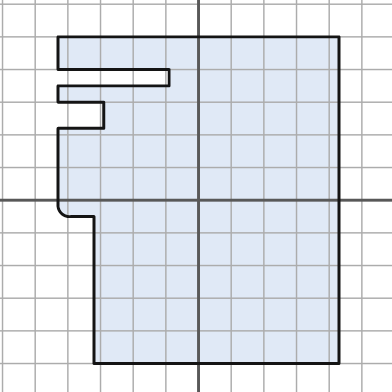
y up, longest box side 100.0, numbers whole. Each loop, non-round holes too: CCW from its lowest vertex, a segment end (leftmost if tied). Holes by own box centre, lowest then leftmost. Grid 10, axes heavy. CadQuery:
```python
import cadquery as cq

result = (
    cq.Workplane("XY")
    .moveTo(-32.0, -50.0)
    .lineTo(43.0, -50.0)
    .lineTo(43.0, 50.0)
    .lineTo(-43.0, 50.0)
    .lineTo(-43.0, 40.0)
    .lineTo(-9.0, 40.0)
    .lineTo(-9.0, 35.0)
    .lineTo(-43.0, 35.0)
    .lineTo(-43.0, 30.0)
    .lineTo(-29.0, 30.0)
    .lineTo(-29.0, 22.0)
    .lineTo(-43.0, 22.0)
    .lineTo(-43.0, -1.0)
    .threePointArc((-42.0, -4.0), (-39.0, -5.0))
    .lineTo(-32.0, -5.0)
    .close()
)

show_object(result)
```